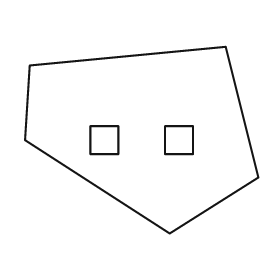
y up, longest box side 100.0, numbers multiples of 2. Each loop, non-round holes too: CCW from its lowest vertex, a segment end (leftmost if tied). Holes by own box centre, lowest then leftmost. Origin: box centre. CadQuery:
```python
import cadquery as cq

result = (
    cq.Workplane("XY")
    .moveTo(12.0, -40.0)
    .lineTo(50.0, -16.0)
    .lineTo(36.0, 40.0)
    .lineTo(-48.0, 32.0)
    .lineTo(-50.0, 0.0)
    .close()
    .moveTo(-22.0, -6.0)
    .lineTo(-10.0, -6.0)
    .lineTo(-10.0, 6.0)
    .lineTo(-22.0, 6.0)
    .close()
    .moveTo(10.0, -6.0)
    .lineTo(22.0, -6.0)
    .lineTo(22.0, 6.0)
    .lineTo(10.0, 6.0)
    .close()
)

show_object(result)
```